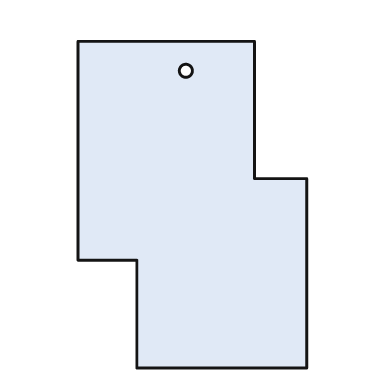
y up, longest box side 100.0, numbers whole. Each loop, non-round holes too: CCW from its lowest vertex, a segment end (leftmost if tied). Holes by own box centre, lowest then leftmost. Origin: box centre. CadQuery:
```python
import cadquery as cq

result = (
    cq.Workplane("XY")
    .moveTo(-17.0, -50.0)
    .lineTo(35.0, -50.0)
    .lineTo(35.0, 8.0)
    .lineTo(19.0, 8.0)
    .lineTo(19.0, 50.0)
    .lineTo(-35.0, 50.0)
    .lineTo(-35.0, -17.0)
    .lineTo(-17.0, -17.0)
    .close()
    .moveTo(-2.0, 41.0)
    .circle(2.0)
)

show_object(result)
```